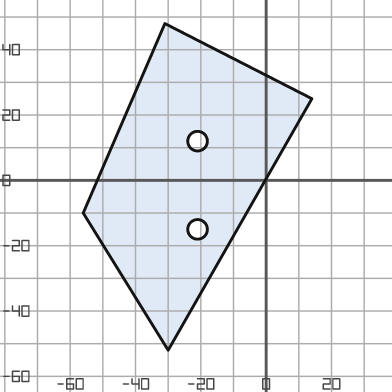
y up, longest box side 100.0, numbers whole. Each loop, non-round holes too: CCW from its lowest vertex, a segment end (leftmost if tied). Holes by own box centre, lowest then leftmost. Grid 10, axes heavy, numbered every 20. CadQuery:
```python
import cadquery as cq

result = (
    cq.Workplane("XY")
    .moveTo(-30.0, -52.0)
    .lineTo(14.0, 25.0)
    .lineTo(-31.0, 48.0)
    .lineTo(-56.0, -10.0)
    .close()
    .moveTo(-21.0, -15.0)
    .circle(3.0)
    .moveTo(-21.0, 12.0)
    .circle(3.0)
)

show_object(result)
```